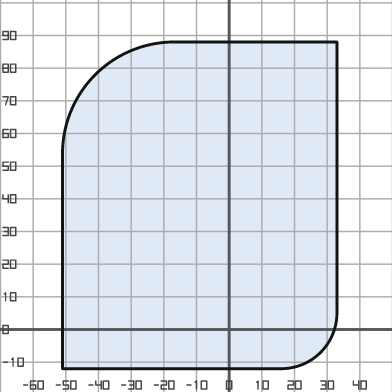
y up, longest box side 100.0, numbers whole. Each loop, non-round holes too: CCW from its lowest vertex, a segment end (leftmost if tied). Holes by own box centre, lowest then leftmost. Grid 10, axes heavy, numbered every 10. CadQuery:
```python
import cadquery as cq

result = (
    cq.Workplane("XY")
    .moveTo(-51.0, -12.0)
    .lineTo(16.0, -12.0)
    .threePointArc((28.0, -7.0), (33.0, 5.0))
    .lineTo(33.0, 88.0)
    .lineTo(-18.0, 88.0)
    .threePointArc((-41.0, 78.0), (-51.0, 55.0))
    .close()
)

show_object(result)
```